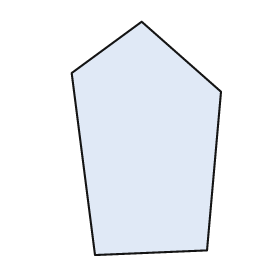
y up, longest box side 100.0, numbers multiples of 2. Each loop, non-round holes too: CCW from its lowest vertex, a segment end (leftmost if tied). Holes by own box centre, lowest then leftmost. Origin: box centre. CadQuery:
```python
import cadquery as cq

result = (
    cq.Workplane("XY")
    .moveTo(-22.0, -50.0)
    .lineTo(26.0, -48.0)
    .lineTo(32.0, 20.0)
    .lineTo(-2.0, 50.0)
    .lineTo(-32.0, 28.0)
    .close()
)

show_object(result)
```